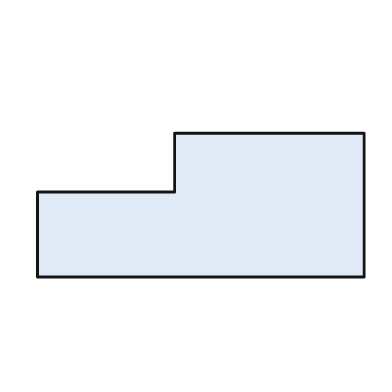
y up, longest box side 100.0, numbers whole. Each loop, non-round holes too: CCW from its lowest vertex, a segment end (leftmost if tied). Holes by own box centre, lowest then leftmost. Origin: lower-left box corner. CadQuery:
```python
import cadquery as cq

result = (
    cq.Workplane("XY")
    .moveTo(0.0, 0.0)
    .lineTo(100.0, 0.0)
    .lineTo(100.0, 44.0)
    .lineTo(42.0, 44.0)
    .lineTo(42.0, 26.0)
    .lineTo(0.0, 26.0)
    .close()
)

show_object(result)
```